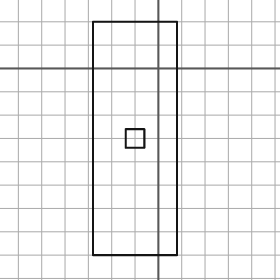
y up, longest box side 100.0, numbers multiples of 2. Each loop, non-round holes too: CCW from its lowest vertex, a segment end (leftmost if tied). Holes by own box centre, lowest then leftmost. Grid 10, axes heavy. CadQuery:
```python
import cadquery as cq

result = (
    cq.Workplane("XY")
    .moveTo(-28.0, -80.0)
    .lineTo(8.0, -80.0)
    .lineTo(8.0, 20.0)
    .lineTo(-28.0, 20.0)
    .close()
    .moveTo(-14.0, -34.0)
    .lineTo(-6.0, -34.0)
    .lineTo(-6.0, -26.0)
    .lineTo(-14.0, -26.0)
    .close()
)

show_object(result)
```